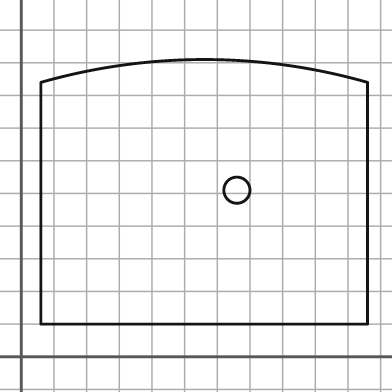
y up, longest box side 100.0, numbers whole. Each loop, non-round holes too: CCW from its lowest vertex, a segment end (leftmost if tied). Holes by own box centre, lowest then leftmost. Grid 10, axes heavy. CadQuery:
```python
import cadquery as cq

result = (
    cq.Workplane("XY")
    .moveTo(6.0, 10.0)
    .lineTo(106.0, 10.0)
    .lineTo(106.0, 84.0)
    .threePointArc((56.0, 91.0), (6.0, 84.0))
    .close()
    .moveTo(66.0, 51.0)
    .circle(4.0)
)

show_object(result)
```